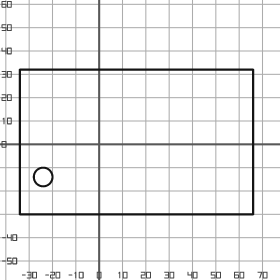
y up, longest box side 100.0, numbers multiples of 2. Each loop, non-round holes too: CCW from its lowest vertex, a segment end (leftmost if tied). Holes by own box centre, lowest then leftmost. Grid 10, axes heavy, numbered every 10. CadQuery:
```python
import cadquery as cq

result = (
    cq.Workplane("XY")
    .moveTo(-34.0, -30.0)
    .lineTo(66.0, -30.0)
    .lineTo(66.0, 32.0)
    .lineTo(-34.0, 32.0)
    .close()
    .moveTo(-24.0, -14.0)
    .circle(4.0)
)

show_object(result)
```